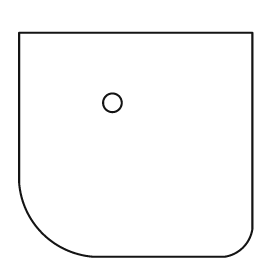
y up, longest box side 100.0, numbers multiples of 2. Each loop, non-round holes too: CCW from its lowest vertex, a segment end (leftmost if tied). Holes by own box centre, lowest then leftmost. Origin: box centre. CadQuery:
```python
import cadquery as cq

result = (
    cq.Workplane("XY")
    .moveTo(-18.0, -48.0)
    .lineTo(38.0, -48.0)
    .threePointArc((46.0, -44.0), (50.0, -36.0))
    .lineTo(50.0, 48.0)
    .lineTo(-50.0, 48.0)
    .lineTo(-50.0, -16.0)
    .threePointArc((-40.0, -38.0), (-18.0, -48.0))
    .close()
    .moveTo(-10.0, 18.0)
    .circle(4.0)
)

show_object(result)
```